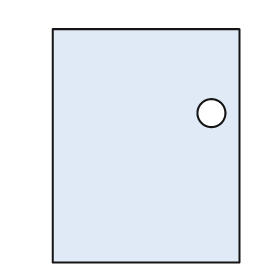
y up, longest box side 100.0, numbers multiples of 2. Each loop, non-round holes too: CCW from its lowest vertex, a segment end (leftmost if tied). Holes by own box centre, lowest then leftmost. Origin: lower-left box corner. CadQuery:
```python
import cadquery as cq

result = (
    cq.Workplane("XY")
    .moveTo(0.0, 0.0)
    .lineTo(80.0, 0.0)
    .lineTo(80.0, 100.0)
    .lineTo(0.0, 100.0)
    .close()
    .moveTo(68.0, 64.0)
    .circle(6.0)
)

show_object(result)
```